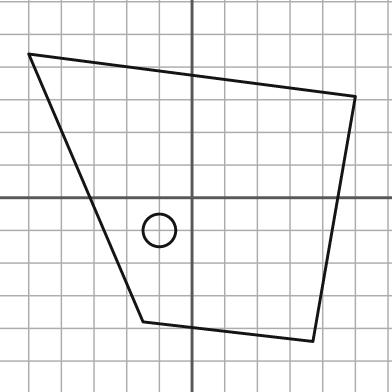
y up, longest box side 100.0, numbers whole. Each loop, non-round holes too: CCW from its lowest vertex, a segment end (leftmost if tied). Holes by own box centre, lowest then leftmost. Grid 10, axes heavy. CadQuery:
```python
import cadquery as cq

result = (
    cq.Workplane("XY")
    .moveTo(37.0, -44.0)
    .lineTo(50.0, 31.0)
    .lineTo(-50.0, 44.0)
    .lineTo(-15.0, -38.0)
    .close()
    .moveTo(-10.0, -10.0)
    .circle(5.0)
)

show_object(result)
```